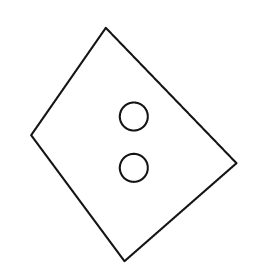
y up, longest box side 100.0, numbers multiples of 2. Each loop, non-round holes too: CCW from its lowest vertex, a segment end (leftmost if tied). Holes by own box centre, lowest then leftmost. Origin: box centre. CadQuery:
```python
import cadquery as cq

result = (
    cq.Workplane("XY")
    .moveTo(-4.0, -50.0)
    .lineTo(44.0, -8.0)
    .lineTo(-12.0, 50.0)
    .lineTo(-44.0, 4.0)
    .close()
    .moveTo(0.0, -10.0)
    .circle(6.0)
    .moveTo(0.0, 12.0)
    .circle(6.0)
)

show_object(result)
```